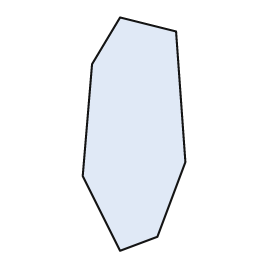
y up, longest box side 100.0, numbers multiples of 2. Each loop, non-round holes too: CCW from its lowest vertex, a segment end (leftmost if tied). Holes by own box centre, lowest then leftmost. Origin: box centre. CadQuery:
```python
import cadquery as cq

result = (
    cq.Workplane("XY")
    .moveTo(-6.0, -50.0)
    .lineTo(10.0, -44.0)
    .lineTo(22.0, -12.0)
    .lineTo(18.0, 44.0)
    .lineTo(-6.0, 50.0)
    .lineTo(-18.0, 30.0)
    .lineTo(-22.0, -18.0)
    .close()
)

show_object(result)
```